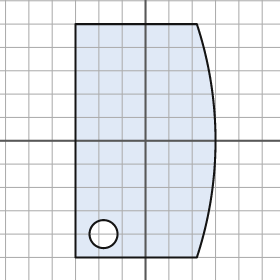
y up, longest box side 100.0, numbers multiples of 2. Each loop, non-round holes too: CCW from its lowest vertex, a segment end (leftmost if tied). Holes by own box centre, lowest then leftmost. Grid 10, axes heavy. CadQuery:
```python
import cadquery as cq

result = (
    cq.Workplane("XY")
    .moveTo(-30.0, -50.0)
    .lineTo(22.0, -50.0)
    .threePointArc((30.0, 0.0), (22.0, 50.0))
    .lineTo(-30.0, 50.0)
    .close()
    .moveTo(-18.0, -40.0)
    .circle(6.0)
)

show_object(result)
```